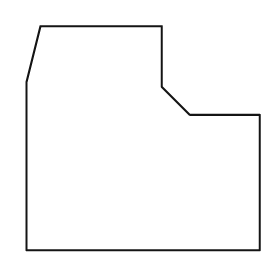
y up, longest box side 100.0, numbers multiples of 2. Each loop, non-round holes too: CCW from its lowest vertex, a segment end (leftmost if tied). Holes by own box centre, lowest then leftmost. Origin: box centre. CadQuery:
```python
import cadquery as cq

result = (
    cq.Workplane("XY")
    .moveTo(-50.0, -48.0)
    .lineTo(50.0, -48.0)
    .lineTo(50.0, 10.0)
    .lineTo(20.0, 10.0)
    .lineTo(8.0, 22.0)
    .lineTo(8.0, 48.0)
    .lineTo(-44.0, 48.0)
    .lineTo(-50.0, 24.0)
    .close()
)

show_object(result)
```